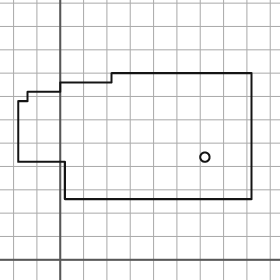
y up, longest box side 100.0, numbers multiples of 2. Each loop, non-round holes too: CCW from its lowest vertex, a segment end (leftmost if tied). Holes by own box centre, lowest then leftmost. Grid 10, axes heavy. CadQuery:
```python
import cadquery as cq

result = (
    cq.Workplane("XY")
    .moveTo(2.0, 26.0)
    .lineTo(82.0, 26.0)
    .lineTo(82.0, 80.0)
    .lineTo(22.0, 80.0)
    .lineTo(22.0, 76.0)
    .lineTo(0.0, 76.0)
    .lineTo(0.0, 72.0)
    .lineTo(-14.0, 72.0)
    .lineTo(-14.0, 68.0)
    .lineTo(-18.0, 68.0)
    .lineTo(-18.0, 42.0)
    .lineTo(2.0, 42.0)
    .close()
    .moveTo(62.0, 44.0)
    .circle(2.0)
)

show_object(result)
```